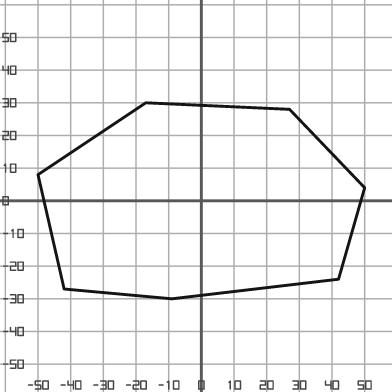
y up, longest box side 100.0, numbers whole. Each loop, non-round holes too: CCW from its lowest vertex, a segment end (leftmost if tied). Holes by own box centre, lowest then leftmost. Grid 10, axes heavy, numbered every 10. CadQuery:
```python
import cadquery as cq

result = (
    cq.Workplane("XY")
    .moveTo(-9.0, -30.0)
    .lineTo(42.0, -24.0)
    .lineTo(50.0, 4.0)
    .lineTo(27.0, 28.0)
    .lineTo(-17.0, 30.0)
    .lineTo(-50.0, 8.0)
    .lineTo(-42.0, -27.0)
    .close()
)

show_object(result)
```